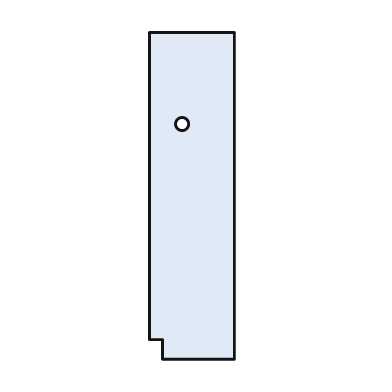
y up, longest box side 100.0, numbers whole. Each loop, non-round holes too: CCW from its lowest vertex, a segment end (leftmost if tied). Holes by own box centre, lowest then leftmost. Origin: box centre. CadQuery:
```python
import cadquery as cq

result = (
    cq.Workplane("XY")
    .moveTo(-9.0, -50.0)
    .lineTo(13.0, -50.0)
    .lineTo(13.0, 50.0)
    .lineTo(-13.0, 50.0)
    .lineTo(-13.0, -44.0)
    .lineTo(-9.0, -44.0)
    .close()
    .moveTo(-3.0, 22.0)
    .circle(2.0)
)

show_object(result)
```